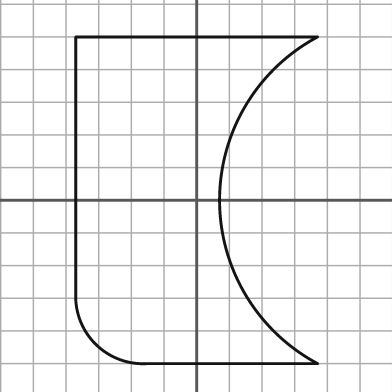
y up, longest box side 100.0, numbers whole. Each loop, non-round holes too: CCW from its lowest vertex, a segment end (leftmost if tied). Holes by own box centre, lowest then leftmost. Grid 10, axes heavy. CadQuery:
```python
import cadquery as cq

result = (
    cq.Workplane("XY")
    .moveTo(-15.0, -50.0)
    .lineTo(37.0, -50.0)
    .threePointArc((7.0, 0.0), (37.0, 50.0))
    .lineTo(-37.0, 50.0)
    .lineTo(-37.0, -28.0)
    .threePointArc((-31.0, -44.0), (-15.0, -50.0))
    .close()
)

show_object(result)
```